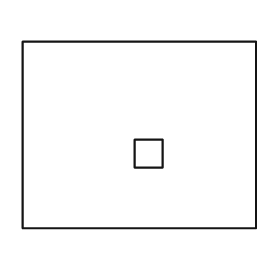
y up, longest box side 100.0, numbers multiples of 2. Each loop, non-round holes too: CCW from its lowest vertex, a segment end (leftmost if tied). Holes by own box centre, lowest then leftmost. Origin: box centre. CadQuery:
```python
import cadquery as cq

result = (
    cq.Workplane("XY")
    .moveTo(-50.0, -40.0)
    .lineTo(50.0, -40.0)
    .lineTo(50.0, 40.0)
    .lineTo(-50.0, 40.0)
    .close()
    .moveTo(-2.0, -14.0)
    .lineTo(10.0, -14.0)
    .lineTo(10.0, -2.0)
    .lineTo(-2.0, -2.0)
    .close()
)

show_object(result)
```